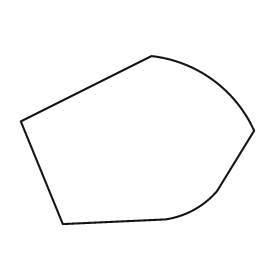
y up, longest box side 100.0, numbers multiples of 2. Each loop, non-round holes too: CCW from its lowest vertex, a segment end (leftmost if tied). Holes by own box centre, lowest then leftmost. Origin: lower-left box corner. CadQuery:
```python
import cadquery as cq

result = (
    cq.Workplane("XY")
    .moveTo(18.0, 0.0)
    .lineTo(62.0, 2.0)
    .threePointArc((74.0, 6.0), (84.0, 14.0))
    .lineTo(100.0, 40.0)
    .threePointArc((82.0, 62.0), (56.0, 72.0))
    .lineTo(0.0, 44.0)
    .close()
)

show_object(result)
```